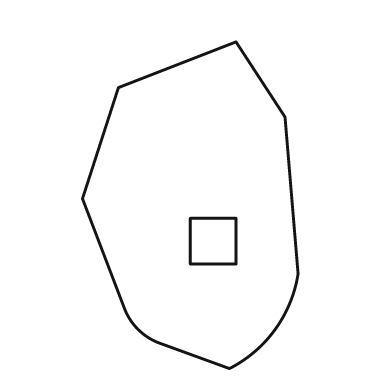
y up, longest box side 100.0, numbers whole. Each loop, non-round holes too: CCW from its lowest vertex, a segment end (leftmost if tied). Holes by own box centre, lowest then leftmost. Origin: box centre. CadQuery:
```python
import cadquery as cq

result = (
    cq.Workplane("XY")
    .moveTo(12.0, -50.0)
    .threePointArc((26.0, -38.0), (33.0, -21.0))
    .lineTo(29.0, 27.0)
    .lineTo(14.0, 50.0)
    .lineTo(-22.0, 36.0)
    .lineTo(-33.0, 2.0)
    .lineTo(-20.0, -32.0)
    .threePointArc((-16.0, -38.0), (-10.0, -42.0))
    .close()
    .moveTo(0.0, -18.0)
    .lineTo(14.0, -18.0)
    .lineTo(14.0, -4.0)
    .lineTo(0.0, -4.0)
    .close()
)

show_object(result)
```